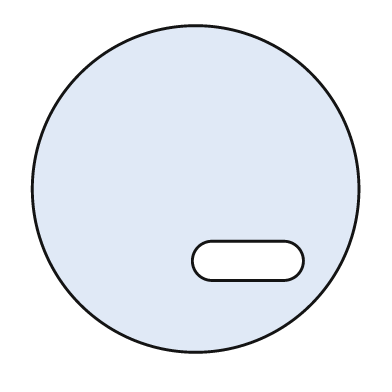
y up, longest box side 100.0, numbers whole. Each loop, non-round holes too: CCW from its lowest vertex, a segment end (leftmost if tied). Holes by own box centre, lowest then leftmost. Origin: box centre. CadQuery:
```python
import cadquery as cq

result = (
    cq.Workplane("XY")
    .moveTo(0.0, 0.0)
    .circle(50.0)
    .moveTo(5.0, -28.0)
    .lineTo(27.0, -28.0)
    .threePointArc((33.0, -22.0), (27.0, -16.0))
    .lineTo(5.0, -16.0)
    .threePointArc((-1.0, -22.0), (5.0, -28.0))
    .close()
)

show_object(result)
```